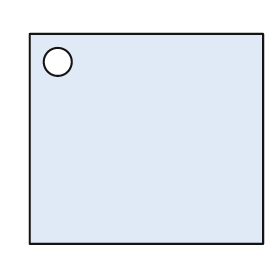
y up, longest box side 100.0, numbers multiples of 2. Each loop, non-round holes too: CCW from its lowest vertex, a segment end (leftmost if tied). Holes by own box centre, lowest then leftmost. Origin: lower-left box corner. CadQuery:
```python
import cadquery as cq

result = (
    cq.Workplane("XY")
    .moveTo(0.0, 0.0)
    .lineTo(100.0, 0.0)
    .lineTo(100.0, 90.0)
    .lineTo(0.0, 90.0)
    .close()
    .moveTo(12.0, 78.0)
    .circle(6.0)
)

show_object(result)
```